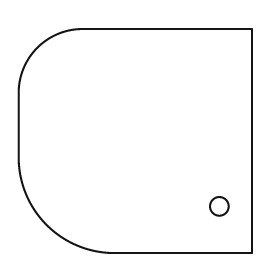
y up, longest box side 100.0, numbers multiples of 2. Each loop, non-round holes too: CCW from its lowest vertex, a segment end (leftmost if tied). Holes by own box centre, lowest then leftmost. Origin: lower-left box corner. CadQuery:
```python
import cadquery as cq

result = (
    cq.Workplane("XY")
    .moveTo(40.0, 0.0)
    .lineTo(100.0, 0.0)
    .lineTo(100.0, 96.0)
    .lineTo(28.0, 96.0)
    .threePointArc((8.0, 88.0), (0.0, 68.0))
    .lineTo(0.0, 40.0)
    .threePointArc((12.0, 12.0), (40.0, 0.0))
    .close()
    .moveTo(86.0, 20.0)
    .circle(4.0)
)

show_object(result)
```